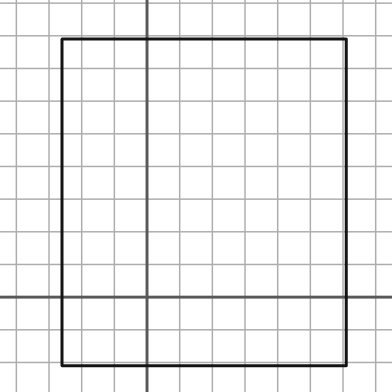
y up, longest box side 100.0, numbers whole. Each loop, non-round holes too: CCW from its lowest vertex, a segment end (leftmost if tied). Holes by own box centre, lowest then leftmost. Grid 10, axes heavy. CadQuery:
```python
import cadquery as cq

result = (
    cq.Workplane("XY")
    .moveTo(-26.0, -21.0)
    .lineTo(61.0, -21.0)
    .lineTo(61.0, 79.0)
    .lineTo(-26.0, 79.0)
    .close()
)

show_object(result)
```